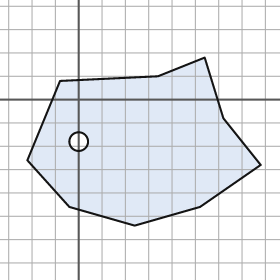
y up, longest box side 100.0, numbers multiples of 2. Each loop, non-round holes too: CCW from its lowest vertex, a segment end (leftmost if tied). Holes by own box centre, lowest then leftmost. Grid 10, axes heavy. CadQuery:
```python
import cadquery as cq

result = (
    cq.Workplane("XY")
    .moveTo(24.0, -54.0)
    .lineTo(52.0, -46.0)
    .lineTo(78.0, -28.0)
    .lineTo(62.0, -8.0)
    .lineTo(54.0, 18.0)
    .lineTo(34.0, 10.0)
    .lineTo(-8.0, 8.0)
    .lineTo(-22.0, -26.0)
    .lineTo(-4.0, -46.0)
    .close()
    .moveTo(0.0, -18.0)
    .circle(4.0)
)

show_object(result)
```